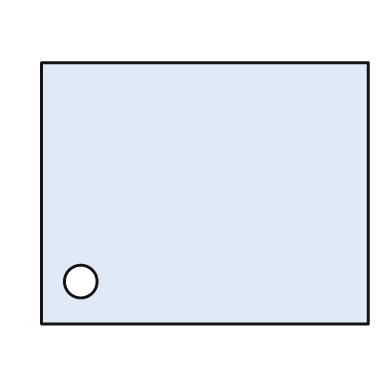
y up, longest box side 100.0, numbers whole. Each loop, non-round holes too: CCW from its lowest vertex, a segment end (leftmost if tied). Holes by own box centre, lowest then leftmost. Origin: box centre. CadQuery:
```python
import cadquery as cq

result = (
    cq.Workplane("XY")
    .moveTo(-50.0, -40.0)
    .lineTo(50.0, -40.0)
    .lineTo(50.0, 40.0)
    .lineTo(-50.0, 40.0)
    .close()
    .moveTo(-38.0, -27.0)
    .circle(5.0)
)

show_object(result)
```